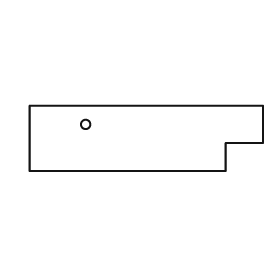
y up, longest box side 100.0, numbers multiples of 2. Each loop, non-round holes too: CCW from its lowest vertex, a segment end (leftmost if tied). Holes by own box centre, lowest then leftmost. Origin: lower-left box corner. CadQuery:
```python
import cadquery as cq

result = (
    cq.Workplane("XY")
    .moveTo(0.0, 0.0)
    .lineTo(84.0, 0.0)
    .lineTo(84.0, 12.0)
    .lineTo(100.0, 12.0)
    .lineTo(100.0, 28.0)
    .lineTo(0.0, 28.0)
    .close()
    .moveTo(24.0, 20.0)
    .circle(2.0)
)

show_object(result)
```